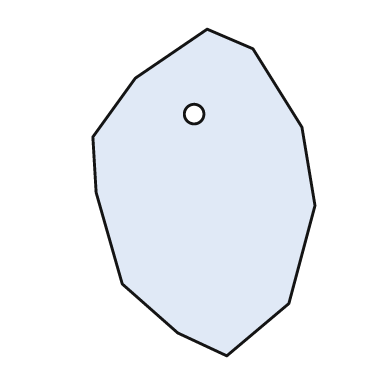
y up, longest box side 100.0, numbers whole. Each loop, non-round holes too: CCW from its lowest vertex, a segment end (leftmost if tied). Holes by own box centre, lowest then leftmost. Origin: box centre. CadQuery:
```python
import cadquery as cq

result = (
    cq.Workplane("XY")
    .moveTo(7.0, -50.0)
    .lineTo(26.0, -34.0)
    .lineTo(34.0, -4.0)
    .lineTo(30.0, 20.0)
    .lineTo(15.0, 44.0)
    .lineTo(1.0, 50.0)
    .lineTo(-21.0, 35.0)
    .lineTo(-34.0, 17.0)
    .lineTo(-33.0, 0.0)
    .lineTo(-25.0, -28.0)
    .lineTo(-8.0, -43.0)
    .close()
    .moveTo(-3.0, 24.0)
    .circle(3.0)
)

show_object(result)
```